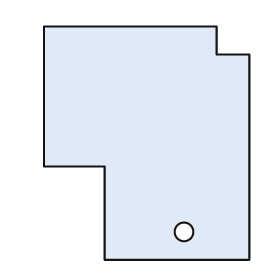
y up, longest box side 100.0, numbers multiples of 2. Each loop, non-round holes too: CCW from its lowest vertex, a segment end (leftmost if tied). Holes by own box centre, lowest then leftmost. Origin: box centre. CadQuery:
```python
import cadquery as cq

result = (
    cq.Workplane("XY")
    .moveTo(-18.0, -50.0)
    .lineTo(44.0, -50.0)
    .lineTo(44.0, 38.0)
    .lineTo(30.0, 38.0)
    .lineTo(30.0, 50.0)
    .lineTo(-44.0, 50.0)
    .lineTo(-44.0, -10.0)
    .lineTo(-18.0, -10.0)
    .close()
    .moveTo(16.0, -38.0)
    .circle(4.0)
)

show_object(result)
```